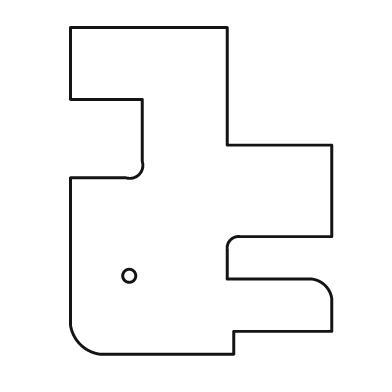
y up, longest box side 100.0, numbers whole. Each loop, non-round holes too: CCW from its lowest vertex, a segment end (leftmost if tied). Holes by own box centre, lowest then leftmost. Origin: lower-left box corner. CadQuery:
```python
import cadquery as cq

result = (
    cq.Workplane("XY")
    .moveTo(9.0, 0.0)
    .lineTo(50.0, 0.0)
    .lineTo(50.0, 7.0)
    .lineTo(80.0, 7.0)
    .lineTo(80.0, 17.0)
    .threePointArc((78.0, 21.0), (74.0, 23.0))
    .lineTo(48.0, 23.0)
    .lineTo(48.0, 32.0)
    .threePointArc((49.0, 35.0), (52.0, 36.0))
    .lineTo(80.0, 36.0)
    .lineTo(80.0, 64.0)
    .lineTo(48.0, 64.0)
    .lineTo(48.0, 100.0)
    .lineTo(0.0, 100.0)
    .lineTo(0.0, 78.0)
    .lineTo(22.0, 78.0)
    .lineTo(22.0, 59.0)
    .threePointArc((21.0, 55.0), (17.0, 54.0))
    .lineTo(0.0, 54.0)
    .lineTo(0.0, 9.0)
    .threePointArc((3.0, 3.0), (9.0, 0.0))
    .close()
    .moveTo(18.0, 24.0)
    .circle(2.0)
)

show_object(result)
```